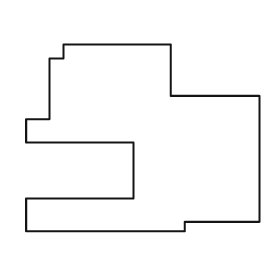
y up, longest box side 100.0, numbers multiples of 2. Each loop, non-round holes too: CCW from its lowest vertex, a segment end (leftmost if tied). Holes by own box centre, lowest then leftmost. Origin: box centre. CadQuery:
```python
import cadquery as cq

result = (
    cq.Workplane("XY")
    .moveTo(-50.0, -40.0)
    .lineTo(18.0, -40.0)
    .lineTo(18.0, -36.0)
    .lineTo(50.0, -36.0)
    .lineTo(50.0, 18.0)
    .lineTo(12.0, 18.0)
    .lineTo(12.0, 40.0)
    .lineTo(-34.0, 40.0)
    .lineTo(-34.0, 34.0)
    .lineTo(-40.0, 34.0)
    .lineTo(-40.0, 8.0)
    .lineTo(-50.0, 8.0)
    .lineTo(-50.0, -2.0)
    .lineTo(-4.0, -2.0)
    .lineTo(-4.0, -26.0)
    .lineTo(-50.0, -26.0)
    .close()
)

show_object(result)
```